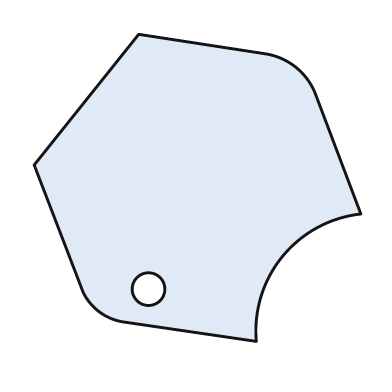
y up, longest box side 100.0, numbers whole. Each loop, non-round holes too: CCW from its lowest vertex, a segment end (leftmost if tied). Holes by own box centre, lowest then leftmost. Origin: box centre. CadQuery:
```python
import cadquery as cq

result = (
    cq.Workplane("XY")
    .moveTo(18.0, -47.0)
    .threePointArc((26.0, -21.0), (50.0, -8.0))
    .lineTo(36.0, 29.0)
    .threePointArc((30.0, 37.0), (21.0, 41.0))
    .lineTo(-18.0, 47.0)
    .lineTo(-50.0, 7.0)
    .lineTo(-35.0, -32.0)
    .threePointArc((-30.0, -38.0), (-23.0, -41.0))
    .close()
    .moveTo(-15.0, -31.0)
    .circle(5.0)
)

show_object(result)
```